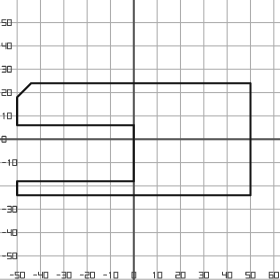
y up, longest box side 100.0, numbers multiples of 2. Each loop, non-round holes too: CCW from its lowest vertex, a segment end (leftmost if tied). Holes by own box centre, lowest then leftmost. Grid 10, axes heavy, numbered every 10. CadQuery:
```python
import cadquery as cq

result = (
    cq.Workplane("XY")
    .moveTo(-50.0, -24.0)
    .lineTo(50.0, -24.0)
    .lineTo(50.0, 24.0)
    .lineTo(-44.0, 24.0)
    .lineTo(-50.0, 18.0)
    .lineTo(-50.0, 6.0)
    .lineTo(0.0, 6.0)
    .lineTo(0.0, -18.0)
    .lineTo(-50.0, -18.0)
    .close()
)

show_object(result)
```